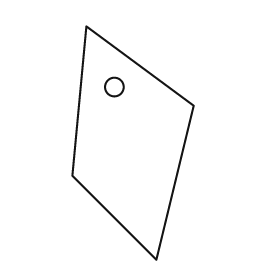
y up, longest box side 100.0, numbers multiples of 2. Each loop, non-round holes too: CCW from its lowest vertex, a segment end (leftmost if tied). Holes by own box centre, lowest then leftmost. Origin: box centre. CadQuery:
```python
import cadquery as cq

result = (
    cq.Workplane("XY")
    .moveTo(10.0, -50.0)
    .lineTo(26.0, 16.0)
    .lineTo(-20.0, 50.0)
    .lineTo(-26.0, -14.0)
    .close()
    .moveTo(-8.0, 24.0)
    .circle(4.0)
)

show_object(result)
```